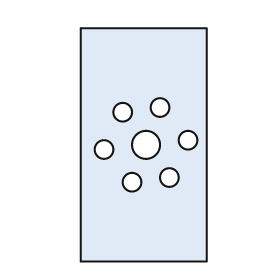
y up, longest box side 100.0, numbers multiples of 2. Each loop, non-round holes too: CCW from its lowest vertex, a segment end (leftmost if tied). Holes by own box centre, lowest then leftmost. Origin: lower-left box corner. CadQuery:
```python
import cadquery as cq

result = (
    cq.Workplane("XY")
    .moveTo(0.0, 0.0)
    .lineTo(54.0, 0.0)
    .lineTo(54.0, 100.0)
    .lineTo(0.0, 100.0)
    .close()
    .moveTo(22.0, 34.0)
    .circle(4.0)
    .moveTo(38.0, 36.0)
    .circle(4.0)
    .moveTo(10.0, 48.0)
    .circle(4.0)
    .moveTo(28.0, 50.0)
    .circle(6.0)
    .moveTo(46.0, 52.0)
    .circle(4.0)
    .moveTo(18.0, 64.0)
    .circle(4.0)
    .moveTo(34.0, 66.0)
    .circle(4.0)
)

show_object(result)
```